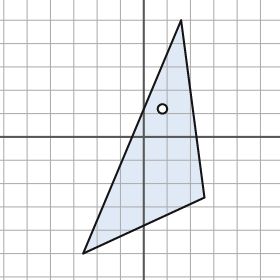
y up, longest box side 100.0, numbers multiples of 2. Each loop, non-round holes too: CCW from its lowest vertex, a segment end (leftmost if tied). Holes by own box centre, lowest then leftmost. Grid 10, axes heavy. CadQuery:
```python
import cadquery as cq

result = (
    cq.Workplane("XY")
    .moveTo(-26.0, -50.0)
    .lineTo(26.0, -26.0)
    .lineTo(16.0, 50.0)
    .close()
    .moveTo(8.0, 12.0)
    .circle(2.0)
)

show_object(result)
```